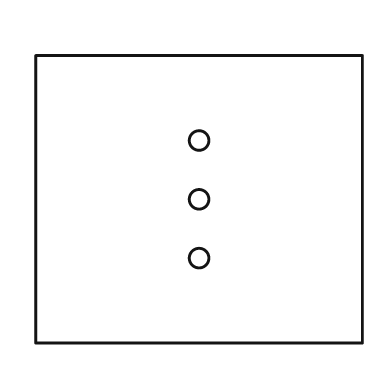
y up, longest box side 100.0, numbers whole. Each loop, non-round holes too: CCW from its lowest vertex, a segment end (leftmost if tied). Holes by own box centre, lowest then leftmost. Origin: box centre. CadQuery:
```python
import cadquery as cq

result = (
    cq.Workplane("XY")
    .moveTo(-50.0, -44.0)
    .lineTo(50.0, -44.0)
    .lineTo(50.0, 44.0)
    .lineTo(-50.0, 44.0)
    .close()
    .moveTo(0.0, -18.0)
    .circle(3.0)
    .moveTo(0.0, 0.0)
    .circle(3.0)
    .moveTo(0.0, 18.0)
    .circle(3.0)
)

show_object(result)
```